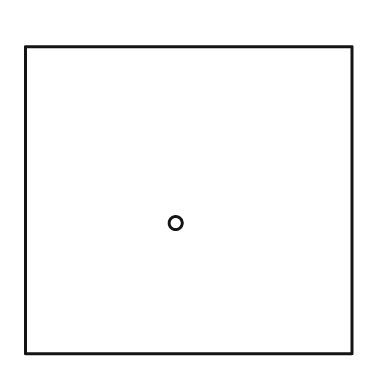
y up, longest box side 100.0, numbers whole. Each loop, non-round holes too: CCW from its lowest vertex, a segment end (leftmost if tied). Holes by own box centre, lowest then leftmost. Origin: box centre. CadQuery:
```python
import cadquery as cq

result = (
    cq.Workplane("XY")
    .moveTo(-50.0, -47.0)
    .lineTo(50.0, -47.0)
    .lineTo(50.0, 47.0)
    .lineTo(-50.0, 47.0)
    .close()
    .moveTo(-4.0, -7.0)
    .circle(2.0)
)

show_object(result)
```